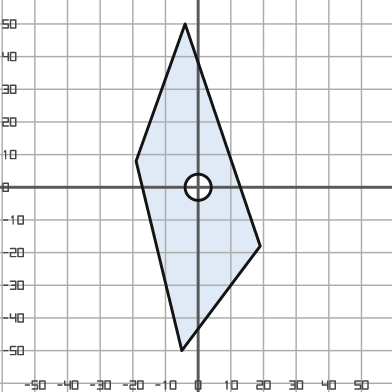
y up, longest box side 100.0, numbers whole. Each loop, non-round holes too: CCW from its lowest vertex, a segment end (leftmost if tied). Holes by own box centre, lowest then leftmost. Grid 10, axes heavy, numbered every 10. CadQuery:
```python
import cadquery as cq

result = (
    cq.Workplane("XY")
    .moveTo(-5.0, -50.0)
    .lineTo(19.0, -18.0)
    .lineTo(-4.0, 50.0)
    .lineTo(-19.0, 8.0)
    .close()
    .moveTo(0.0, 0.0)
    .circle(4.0)
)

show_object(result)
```